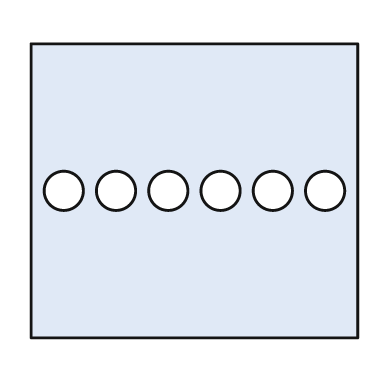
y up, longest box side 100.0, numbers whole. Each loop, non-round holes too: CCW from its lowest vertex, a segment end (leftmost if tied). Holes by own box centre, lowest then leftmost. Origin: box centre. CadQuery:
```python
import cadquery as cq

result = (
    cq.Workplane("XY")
    .moveTo(-50.0, -45.0)
    .lineTo(50.0, -45.0)
    .lineTo(50.0, 45.0)
    .lineTo(-50.0, 45.0)
    .close()
    .moveTo(-40.0, 0.0)
    .circle(6.0)
    .moveTo(-24.0, 0.0)
    .circle(6.0)
    .moveTo(-8.0, 0.0)
    .circle(6.0)
    .moveTo(8.0, 0.0)
    .circle(6.0)
    .moveTo(24.0, 0.0)
    .circle(6.0)
    .moveTo(40.0, 0.0)
    .circle(6.0)
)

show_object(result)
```